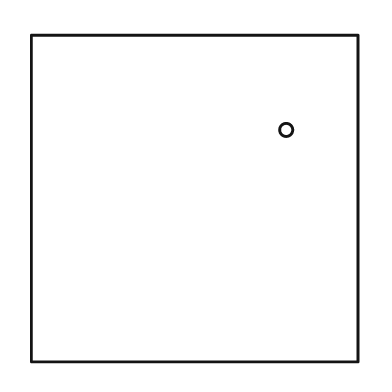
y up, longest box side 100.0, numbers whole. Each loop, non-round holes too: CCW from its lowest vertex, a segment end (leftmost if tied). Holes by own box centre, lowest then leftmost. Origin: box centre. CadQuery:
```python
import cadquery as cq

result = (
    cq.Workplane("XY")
    .moveTo(-50.0, -50.0)
    .lineTo(50.0, -50.0)
    .lineTo(50.0, 50.0)
    .lineTo(-50.0, 50.0)
    .close()
    .moveTo(28.0, 21.0)
    .circle(2.0)
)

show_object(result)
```